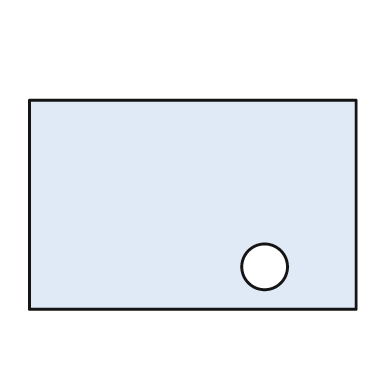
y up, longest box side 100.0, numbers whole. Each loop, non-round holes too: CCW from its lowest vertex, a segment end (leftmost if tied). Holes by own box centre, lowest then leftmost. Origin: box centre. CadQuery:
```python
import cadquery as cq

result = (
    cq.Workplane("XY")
    .moveTo(-50.0, -32.0)
    .lineTo(50.0, -32.0)
    .lineTo(50.0, 32.0)
    .lineTo(-50.0, 32.0)
    .close()
    .moveTo(22.0, -19.0)
    .circle(7.0)
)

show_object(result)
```